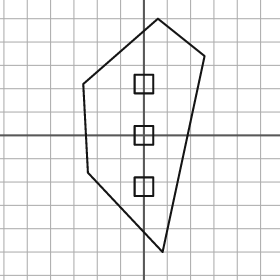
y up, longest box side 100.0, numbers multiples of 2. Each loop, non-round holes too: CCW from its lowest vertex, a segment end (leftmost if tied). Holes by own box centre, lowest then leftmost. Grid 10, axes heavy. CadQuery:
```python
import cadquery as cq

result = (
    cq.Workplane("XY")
    .moveTo(8.0, -50.0)
    .lineTo(26.0, 34.0)
    .lineTo(6.0, 50.0)
    .lineTo(-26.0, 22.0)
    .lineTo(-24.0, -16.0)
    .close()
    .moveTo(-4.0, -26.0)
    .lineTo(4.0, -26.0)
    .lineTo(4.0, -18.0)
    .lineTo(-4.0, -18.0)
    .close()
    .moveTo(-4.0, -4.0)
    .lineTo(4.0, -4.0)
    .lineTo(4.0, 4.0)
    .lineTo(-4.0, 4.0)
    .close()
    .moveTo(-4.0, 18.0)
    .lineTo(4.0, 18.0)
    .lineTo(4.0, 26.0)
    .lineTo(-4.0, 26.0)
    .close()
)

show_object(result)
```